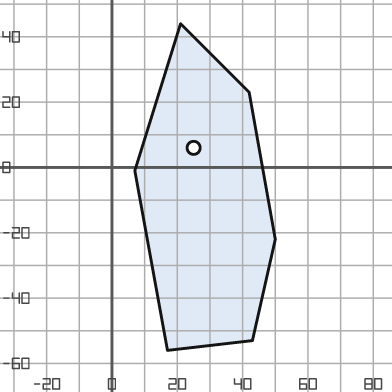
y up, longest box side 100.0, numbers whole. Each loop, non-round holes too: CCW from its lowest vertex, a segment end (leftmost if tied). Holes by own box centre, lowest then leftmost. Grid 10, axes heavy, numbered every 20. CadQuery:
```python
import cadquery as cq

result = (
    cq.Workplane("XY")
    .moveTo(17.0, -56.0)
    .lineTo(43.0, -53.0)
    .lineTo(50.0, -22.0)
    .lineTo(42.0, 23.0)
    .lineTo(21.0, 44.0)
    .lineTo(7.0, -1.0)
    .close()
    .moveTo(25.0, 6.0)
    .circle(2.0)
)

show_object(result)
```